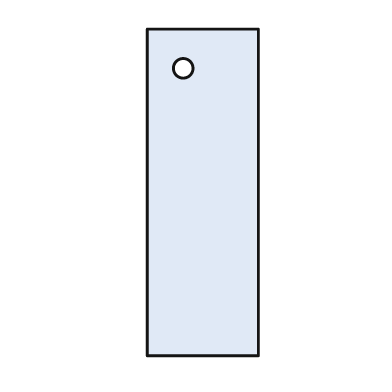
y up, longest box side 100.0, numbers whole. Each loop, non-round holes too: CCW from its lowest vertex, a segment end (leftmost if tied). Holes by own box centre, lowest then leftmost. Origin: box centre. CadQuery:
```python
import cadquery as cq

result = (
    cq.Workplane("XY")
    .moveTo(-17.0, -50.0)
    .lineTo(17.0, -50.0)
    .lineTo(17.0, 50.0)
    .lineTo(-17.0, 50.0)
    .close()
    .moveTo(-6.0, 38.0)
    .circle(3.0)
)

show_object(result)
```